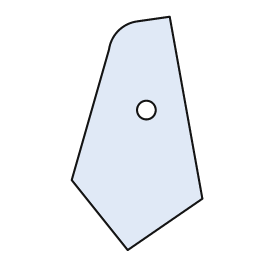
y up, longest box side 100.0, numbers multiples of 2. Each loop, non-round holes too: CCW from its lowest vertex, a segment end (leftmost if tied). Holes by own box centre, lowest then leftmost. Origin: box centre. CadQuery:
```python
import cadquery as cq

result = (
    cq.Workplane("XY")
    .moveTo(-4.0, -50.0)
    .lineTo(28.0, -28.0)
    .lineTo(14.0, 50.0)
    .lineTo(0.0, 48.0)
    .threePointArc((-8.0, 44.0), (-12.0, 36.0))
    .lineTo(-28.0, -20.0)
    .close()
    .moveTo(4.0, 10.0)
    .circle(4.0)
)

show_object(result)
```